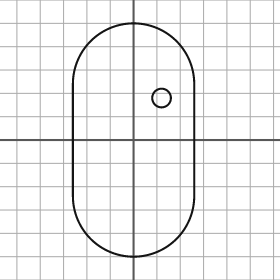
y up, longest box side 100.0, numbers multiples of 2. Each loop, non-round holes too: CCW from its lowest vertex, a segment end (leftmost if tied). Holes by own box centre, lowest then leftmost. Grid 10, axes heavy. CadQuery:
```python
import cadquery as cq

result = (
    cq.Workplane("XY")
    .moveTo(-26.0, -24.0)
    .threePointArc((0.0, -50.0), (26.0, -24.0))
    .lineTo(26.0, 24.0)
    .threePointArc((0.0, 50.0), (-26.0, 24.0))
    .close()
    .moveTo(12.0, 18.0)
    .circle(4.0)
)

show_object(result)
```